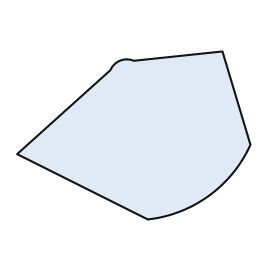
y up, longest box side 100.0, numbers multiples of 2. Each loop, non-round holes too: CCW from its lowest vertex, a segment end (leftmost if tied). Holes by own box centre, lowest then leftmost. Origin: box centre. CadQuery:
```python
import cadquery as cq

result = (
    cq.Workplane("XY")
    .moveTo(6.0, -36.0)
    .threePointArc((32.0, -26.0), (50.0, -4.0))
    .lineTo(38.0, 36.0)
    .lineTo(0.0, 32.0)
    .threePointArc((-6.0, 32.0), (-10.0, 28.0))
    .lineTo(-50.0, -8.0)
    .close()
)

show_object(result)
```